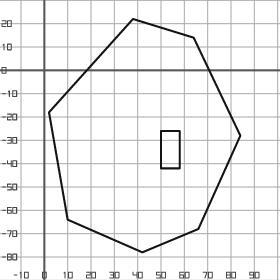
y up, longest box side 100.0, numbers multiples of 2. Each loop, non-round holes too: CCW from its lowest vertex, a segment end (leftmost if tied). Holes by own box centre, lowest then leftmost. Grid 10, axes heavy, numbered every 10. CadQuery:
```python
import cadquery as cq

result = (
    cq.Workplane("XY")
    .moveTo(42.0, -78.0)
    .lineTo(66.0, -68.0)
    .lineTo(84.0, -28.0)
    .lineTo(64.0, 14.0)
    .lineTo(38.0, 22.0)
    .lineTo(2.0, -18.0)
    .lineTo(10.0, -64.0)
    .close()
    .moveTo(50.0, -42.0)
    .lineTo(58.0, -42.0)
    .lineTo(58.0, -26.0)
    .lineTo(50.0, -26.0)
    .close()
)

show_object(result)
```